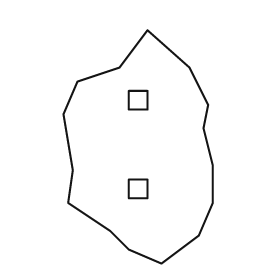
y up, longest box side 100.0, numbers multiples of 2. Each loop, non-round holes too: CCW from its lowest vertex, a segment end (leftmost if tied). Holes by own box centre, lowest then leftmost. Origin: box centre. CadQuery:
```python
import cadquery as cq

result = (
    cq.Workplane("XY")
    .moveTo(10.0, -50.0)
    .lineTo(26.0, -38.0)
    .lineTo(32.0, -24.0)
    .lineTo(32.0, -8.0)
    .lineTo(28.0, 8.0)
    .lineTo(30.0, 18.0)
    .lineTo(22.0, 34.0)
    .lineTo(4.0, 50.0)
    .lineTo(-8.0, 34.0)
    .lineTo(-26.0, 28.0)
    .lineTo(-32.0, 14.0)
    .lineTo(-28.0, -10.0)
    .lineTo(-30.0, -24.0)
    .lineTo(-12.0, -36.0)
    .lineTo(-4.0, -44.0)
    .close()
    .moveTo(-4.0, -22.0)
    .lineTo(4.0, -22.0)
    .lineTo(4.0, -14.0)
    .lineTo(-4.0, -14.0)
    .close()
    .moveTo(-4.0, 16.0)
    .lineTo(4.0, 16.0)
    .lineTo(4.0, 24.0)
    .lineTo(-4.0, 24.0)
    .close()
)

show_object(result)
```